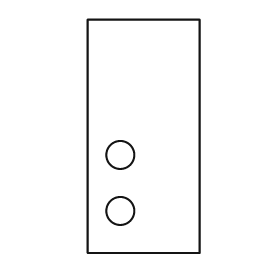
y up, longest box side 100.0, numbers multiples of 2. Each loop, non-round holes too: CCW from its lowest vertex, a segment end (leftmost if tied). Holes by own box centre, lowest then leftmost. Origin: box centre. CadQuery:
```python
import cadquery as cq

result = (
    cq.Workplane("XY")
    .moveTo(-24.0, -50.0)
    .lineTo(24.0, -50.0)
    .lineTo(24.0, 50.0)
    .lineTo(-24.0, 50.0)
    .close()
    .moveTo(-10.0, -32.0)
    .circle(6.0)
    .moveTo(-10.0, -8.0)
    .circle(6.0)
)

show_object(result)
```